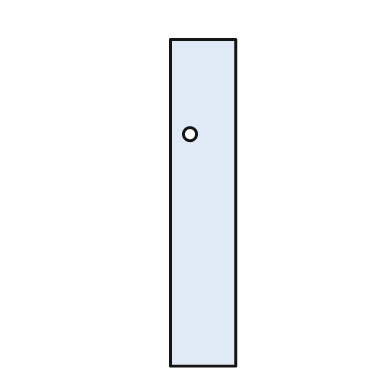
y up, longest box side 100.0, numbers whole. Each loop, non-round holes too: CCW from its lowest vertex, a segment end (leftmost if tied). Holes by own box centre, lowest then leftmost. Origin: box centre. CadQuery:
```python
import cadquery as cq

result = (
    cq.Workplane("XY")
    .moveTo(-10.0, -50.0)
    .lineTo(10.0, -50.0)
    .lineTo(10.0, 50.0)
    .lineTo(-10.0, 50.0)
    .close()
    .moveTo(-4.0, 21.0)
    .circle(2.0)
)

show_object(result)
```